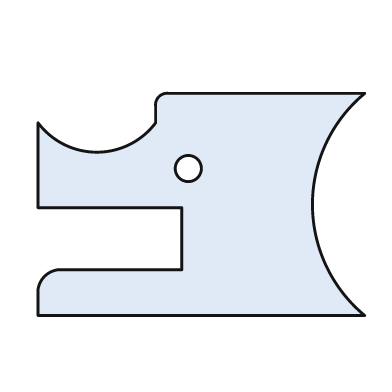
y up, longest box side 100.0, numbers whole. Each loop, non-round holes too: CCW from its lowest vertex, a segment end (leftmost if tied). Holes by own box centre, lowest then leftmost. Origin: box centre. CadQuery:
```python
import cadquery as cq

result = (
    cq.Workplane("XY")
    .moveTo(-50.0, -34.0)
    .lineTo(50.0, -34.0)
    .threePointArc((34.0, 0.0), (50.0, 34.0))
    .lineTo(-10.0, 34.0)
    .threePointArc((-13.0, 33.0), (-14.0, 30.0))
    .lineTo(-14.0, 25.0)
    .threePointArc((-32.0, 16.0), (-50.0, 25.0))
    .lineTo(-50.0, -1.0)
    .lineTo(-6.0, -1.0)
    .lineTo(-6.0, -20.0)
    .lineTo(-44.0, -20.0)
    .threePointArc((-48.0, -22.0), (-50.0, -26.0))
    .close()
    .moveTo(-4.0, 11.0)
    .circle(4.0)
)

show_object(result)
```